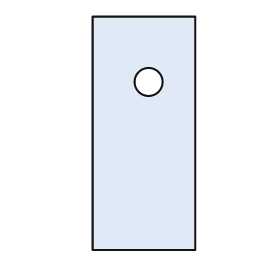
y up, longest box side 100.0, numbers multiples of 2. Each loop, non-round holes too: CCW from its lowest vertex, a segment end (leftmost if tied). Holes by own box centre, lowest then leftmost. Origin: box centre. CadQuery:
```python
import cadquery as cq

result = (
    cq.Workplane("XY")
    .moveTo(-22.0, -50.0)
    .lineTo(22.0, -50.0)
    .lineTo(22.0, 50.0)
    .lineTo(-22.0, 50.0)
    .close()
    .moveTo(2.0, 22.0)
    .circle(6.0)
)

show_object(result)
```